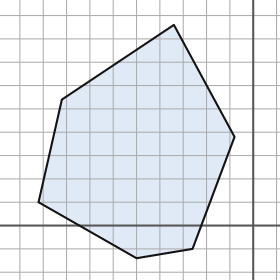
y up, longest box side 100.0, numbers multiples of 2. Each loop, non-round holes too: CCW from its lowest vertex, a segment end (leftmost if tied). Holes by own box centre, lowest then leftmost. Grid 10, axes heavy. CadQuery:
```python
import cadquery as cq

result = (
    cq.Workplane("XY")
    .moveTo(-50.0, -14.0)
    .lineTo(-26.0, -10.0)
    .lineTo(-8.0, 38.0)
    .lineTo(-34.0, 86.0)
    .lineTo(-82.0, 54.0)
    .lineTo(-92.0, 10.0)
    .close()
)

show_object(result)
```